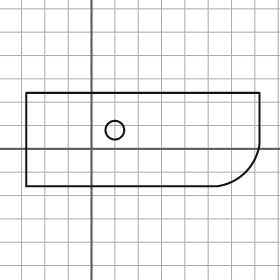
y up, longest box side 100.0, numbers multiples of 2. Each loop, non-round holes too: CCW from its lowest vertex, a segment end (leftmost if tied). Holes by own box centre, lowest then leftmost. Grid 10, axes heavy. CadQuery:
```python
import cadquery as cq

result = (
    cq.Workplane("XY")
    .moveTo(-28.0, -16.0)
    .lineTo(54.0, -16.0)
    .threePointArc((66.0, -10.0), (72.0, 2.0))
    .lineTo(72.0, 24.0)
    .lineTo(-28.0, 24.0)
    .close()
    .moveTo(10.0, 8.0)
    .circle(4.0)
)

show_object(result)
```